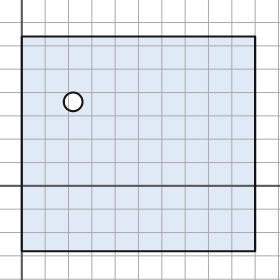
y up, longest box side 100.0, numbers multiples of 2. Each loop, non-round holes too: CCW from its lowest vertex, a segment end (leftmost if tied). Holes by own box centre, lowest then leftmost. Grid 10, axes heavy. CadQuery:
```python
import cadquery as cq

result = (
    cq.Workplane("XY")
    .moveTo(0.0, -28.0)
    .lineTo(100.0, -28.0)
    .lineTo(100.0, 64.0)
    .lineTo(0.0, 64.0)
    .close()
    .moveTo(22.0, 36.0)
    .circle(4.0)
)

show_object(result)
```